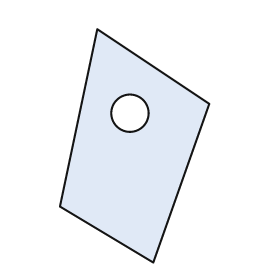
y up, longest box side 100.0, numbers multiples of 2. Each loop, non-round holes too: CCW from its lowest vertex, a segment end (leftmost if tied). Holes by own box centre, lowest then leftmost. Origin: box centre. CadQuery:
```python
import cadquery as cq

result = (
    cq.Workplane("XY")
    .moveTo(8.0, -50.0)
    .lineTo(32.0, 18.0)
    .lineTo(-16.0, 50.0)
    .lineTo(-32.0, -26.0)
    .close()
    .moveTo(-2.0, 14.0)
    .circle(8.0)
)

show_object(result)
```